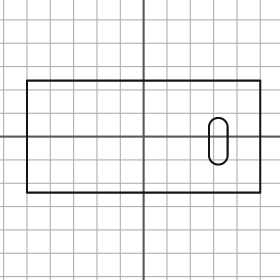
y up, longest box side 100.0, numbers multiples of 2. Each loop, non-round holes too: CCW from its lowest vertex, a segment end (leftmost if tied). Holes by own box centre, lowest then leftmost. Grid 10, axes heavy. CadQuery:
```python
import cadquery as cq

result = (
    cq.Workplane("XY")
    .moveTo(-50.0, -24.0)
    .lineTo(50.0, -24.0)
    .lineTo(50.0, 24.0)
    .lineTo(-50.0, 24.0)
    .close()
    .moveTo(28.0, -8.0)
    .threePointArc((32.0, -12.0), (36.0, -8.0))
    .lineTo(36.0, 4.0)
    .threePointArc((32.0, 8.0), (28.0, 4.0))
    .close()
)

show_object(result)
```